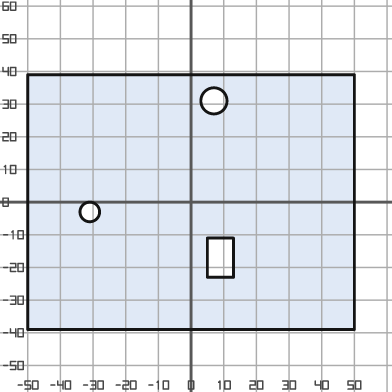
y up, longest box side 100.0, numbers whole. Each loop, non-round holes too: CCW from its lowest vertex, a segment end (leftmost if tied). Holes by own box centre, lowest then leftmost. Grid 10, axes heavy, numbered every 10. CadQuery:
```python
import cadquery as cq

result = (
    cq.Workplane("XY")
    .moveTo(-50.0, -39.0)
    .lineTo(50.0, -39.0)
    .lineTo(50.0, 39.0)
    .lineTo(-50.0, 39.0)
    .close()
    .moveTo(5.0, -23.0)
    .lineTo(13.0, -23.0)
    .lineTo(13.0, -11.0)
    .lineTo(5.0, -11.0)
    .close()
    .moveTo(-31.0, -3.0)
    .circle(3.0)
    .moveTo(7.0, 31.0)
    .circle(4.0)
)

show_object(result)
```